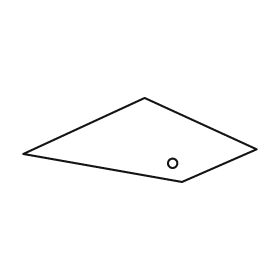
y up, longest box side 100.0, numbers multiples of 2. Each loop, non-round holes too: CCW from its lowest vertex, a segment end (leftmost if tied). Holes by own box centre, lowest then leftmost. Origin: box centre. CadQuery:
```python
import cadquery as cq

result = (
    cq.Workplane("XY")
    .moveTo(18.0, -18.0)
    .lineTo(50.0, -4.0)
    .lineTo(2.0, 18.0)
    .lineTo(-50.0, -6.0)
    .close()
    .moveTo(14.0, -10.0)
    .circle(2.0)
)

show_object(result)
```